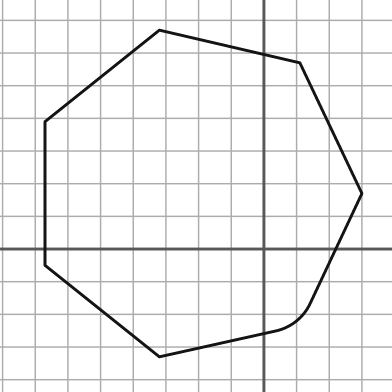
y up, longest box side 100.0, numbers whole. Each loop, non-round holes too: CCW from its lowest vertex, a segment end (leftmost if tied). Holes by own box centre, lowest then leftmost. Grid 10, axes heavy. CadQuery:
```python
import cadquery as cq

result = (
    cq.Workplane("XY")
    .moveTo(-32.0, -33.0)
    .lineTo(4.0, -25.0)
    .threePointArc((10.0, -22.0), (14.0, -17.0))
    .lineTo(30.0, 17.0)
    .lineTo(11.0, 57.0)
    .lineTo(-32.0, 67.0)
    .lineTo(-67.0, 39.0)
    .lineTo(-67.0, -5.0)
    .close()
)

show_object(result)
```